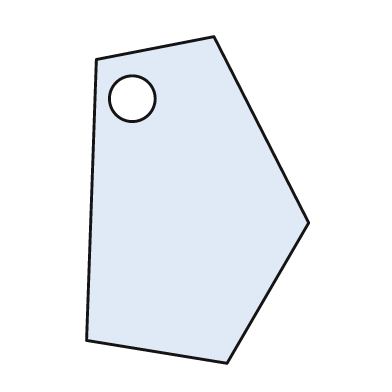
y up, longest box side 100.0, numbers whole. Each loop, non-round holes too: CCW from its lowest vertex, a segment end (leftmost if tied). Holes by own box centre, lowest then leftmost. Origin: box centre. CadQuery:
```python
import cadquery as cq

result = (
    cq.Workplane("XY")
    .moveTo(9.0, -50.0)
    .lineTo(34.0, -7.0)
    .lineTo(5.0, 50.0)
    .lineTo(-31.0, 43.0)
    .lineTo(-34.0, -43.0)
    .close()
    .moveTo(-20.0, 31.0)
    .circle(7.0)
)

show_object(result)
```